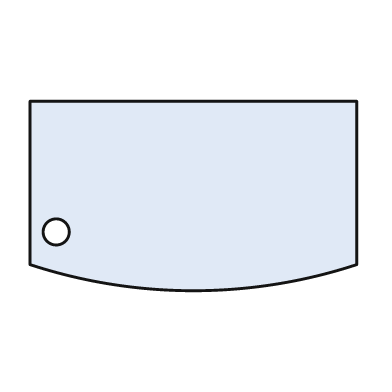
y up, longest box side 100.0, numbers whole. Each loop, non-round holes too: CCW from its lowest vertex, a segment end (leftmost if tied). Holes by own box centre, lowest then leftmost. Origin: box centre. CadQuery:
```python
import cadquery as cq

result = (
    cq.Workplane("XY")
    .moveTo(-50.0, -21.0)
    .threePointArc((0.0, -29.0), (50.0, -21.0))
    .lineTo(50.0, 29.0)
    .lineTo(-50.0, 29.0)
    .close()
    .moveTo(-42.0, -11.0)
    .circle(4.0)
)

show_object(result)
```